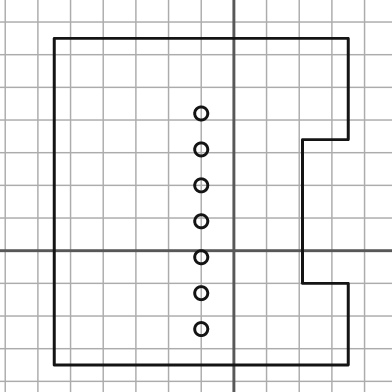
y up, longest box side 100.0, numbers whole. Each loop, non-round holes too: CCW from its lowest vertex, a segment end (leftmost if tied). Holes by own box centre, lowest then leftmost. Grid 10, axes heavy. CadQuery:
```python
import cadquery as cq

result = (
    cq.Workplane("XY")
    .moveTo(-55.0, -35.0)
    .lineTo(35.0, -35.0)
    .lineTo(35.0, -10.0)
    .lineTo(21.0, -10.0)
    .lineTo(21.0, 34.0)
    .lineTo(35.0, 34.0)
    .lineTo(35.0, 65.0)
    .lineTo(-55.0, 65.0)
    .close()
    .moveTo(-10.0, -24.0)
    .circle(2.0)
    .moveTo(-10.0, -13.0)
    .circle(2.0)
    .moveTo(-10.0, -2.0)
    .circle(2.0)
    .moveTo(-10.0, 9.0)
    .circle(2.0)
    .moveTo(-10.0, 20.0)
    .circle(2.0)
    .moveTo(-10.0, 31.0)
    .circle(2.0)
    .moveTo(-10.0, 42.0)
    .circle(2.0)
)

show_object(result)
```